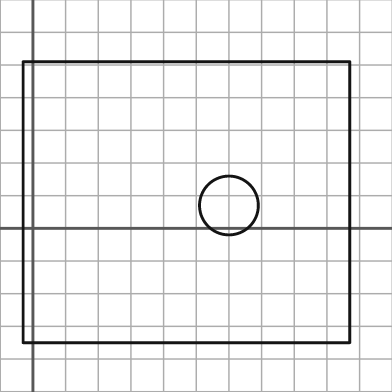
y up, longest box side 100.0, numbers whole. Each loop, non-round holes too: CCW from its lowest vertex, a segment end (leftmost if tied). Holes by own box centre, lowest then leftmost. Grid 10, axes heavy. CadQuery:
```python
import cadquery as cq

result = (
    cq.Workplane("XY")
    .moveTo(-3.0, -35.0)
    .lineTo(97.0, -35.0)
    .lineTo(97.0, 51.0)
    .lineTo(-3.0, 51.0)
    .close()
    .moveTo(60.0, 7.0)
    .circle(9.0)
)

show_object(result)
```